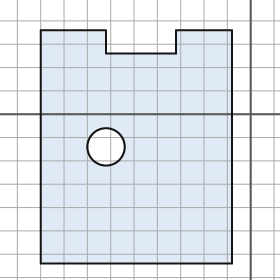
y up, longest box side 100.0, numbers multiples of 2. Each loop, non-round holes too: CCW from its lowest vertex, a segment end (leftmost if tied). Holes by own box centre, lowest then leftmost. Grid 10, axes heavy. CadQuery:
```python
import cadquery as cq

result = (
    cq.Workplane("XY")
    .moveTo(-90.0, -64.0)
    .lineTo(-8.0, -64.0)
    .lineTo(-8.0, 36.0)
    .lineTo(-32.0, 36.0)
    .lineTo(-32.0, 26.0)
    .lineTo(-62.0, 26.0)
    .lineTo(-62.0, 36.0)
    .lineTo(-90.0, 36.0)
    .close()
    .moveTo(-62.0, -14.0)
    .circle(8.0)
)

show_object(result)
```